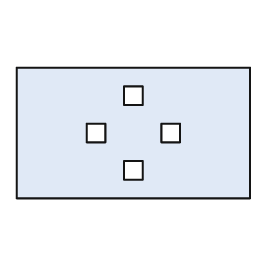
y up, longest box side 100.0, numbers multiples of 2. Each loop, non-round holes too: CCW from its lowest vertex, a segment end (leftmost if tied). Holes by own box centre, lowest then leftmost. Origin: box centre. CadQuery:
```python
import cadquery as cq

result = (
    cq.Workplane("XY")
    .moveTo(-50.0, -28.0)
    .lineTo(50.0, -28.0)
    .lineTo(50.0, 28.0)
    .lineTo(-50.0, 28.0)
    .close()
    .moveTo(-4.0, -20.0)
    .lineTo(4.0, -20.0)
    .lineTo(4.0, -12.0)
    .lineTo(-4.0, -12.0)
    .close()
    .moveTo(-20.0, -4.0)
    .lineTo(-12.0, -4.0)
    .lineTo(-12.0, 4.0)
    .lineTo(-20.0, 4.0)
    .close()
    .moveTo(12.0, -4.0)
    .lineTo(20.0, -4.0)
    .lineTo(20.0, 4.0)
    .lineTo(12.0, 4.0)
    .close()
    .moveTo(-4.0, 12.0)
    .lineTo(4.0, 12.0)
    .lineTo(4.0, 20.0)
    .lineTo(-4.0, 20.0)
    .close()
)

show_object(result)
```